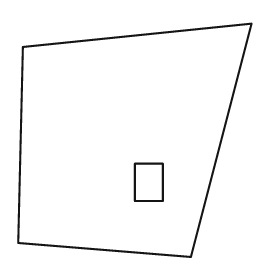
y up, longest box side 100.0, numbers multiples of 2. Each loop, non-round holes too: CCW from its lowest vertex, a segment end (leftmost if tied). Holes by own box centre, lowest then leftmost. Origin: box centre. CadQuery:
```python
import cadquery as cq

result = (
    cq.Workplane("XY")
    .moveTo(24.0, -50.0)
    .lineTo(50.0, 50.0)
    .lineTo(-48.0, 40.0)
    .lineTo(-50.0, -44.0)
    .close()
    .moveTo(0.0, -26.0)
    .lineTo(12.0, -26.0)
    .lineTo(12.0, -10.0)
    .lineTo(0.0, -10.0)
    .close()
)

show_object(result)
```